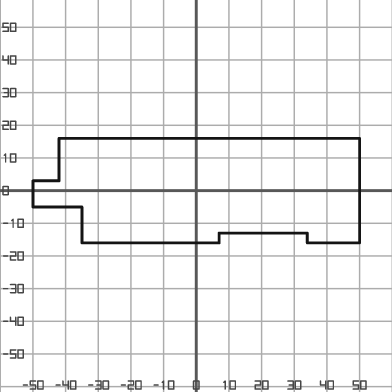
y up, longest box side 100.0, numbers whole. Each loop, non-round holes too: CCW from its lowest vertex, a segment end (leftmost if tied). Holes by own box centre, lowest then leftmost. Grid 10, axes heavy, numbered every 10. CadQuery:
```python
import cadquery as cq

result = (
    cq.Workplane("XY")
    .moveTo(-35.0, -16.0)
    .lineTo(7.0, -16.0)
    .lineTo(7.0, -13.0)
    .lineTo(34.0, -13.0)
    .lineTo(34.0, -16.0)
    .lineTo(50.0, -16.0)
    .lineTo(50.0, 16.0)
    .lineTo(-42.0, 16.0)
    .lineTo(-42.0, 3.0)
    .lineTo(-50.0, 3.0)
    .lineTo(-50.0, -5.0)
    .lineTo(-35.0, -5.0)
    .close()
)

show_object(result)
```